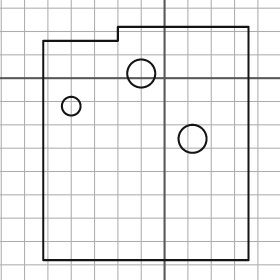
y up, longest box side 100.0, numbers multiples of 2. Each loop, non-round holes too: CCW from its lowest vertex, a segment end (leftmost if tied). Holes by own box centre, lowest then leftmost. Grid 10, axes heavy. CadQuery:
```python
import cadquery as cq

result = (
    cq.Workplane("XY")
    .moveTo(-52.0, -78.0)
    .lineTo(36.0, -78.0)
    .lineTo(36.0, 22.0)
    .lineTo(-20.0, 22.0)
    .lineTo(-20.0, 16.0)
    .lineTo(-52.0, 16.0)
    .close()
    .moveTo(12.0, -26.0)
    .circle(6.0)
    .moveTo(-40.0, -12.0)
    .circle(4.0)
    .moveTo(-10.0, 2.0)
    .circle(6.0)
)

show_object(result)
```